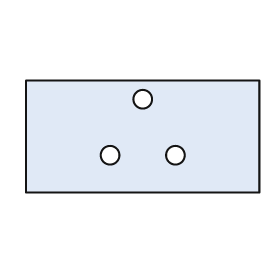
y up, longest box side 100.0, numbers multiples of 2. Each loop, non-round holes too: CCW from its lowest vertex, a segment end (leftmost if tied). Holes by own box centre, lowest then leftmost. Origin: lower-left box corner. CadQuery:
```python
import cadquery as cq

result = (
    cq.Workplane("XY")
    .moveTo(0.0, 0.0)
    .lineTo(100.0, 0.0)
    .lineTo(100.0, 48.0)
    .lineTo(0.0, 48.0)
    .close()
    .moveTo(36.0, 16.0)
    .circle(4.0)
    .moveTo(64.0, 16.0)
    .circle(4.0)
    .moveTo(50.0, 40.0)
    .circle(4.0)
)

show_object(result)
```